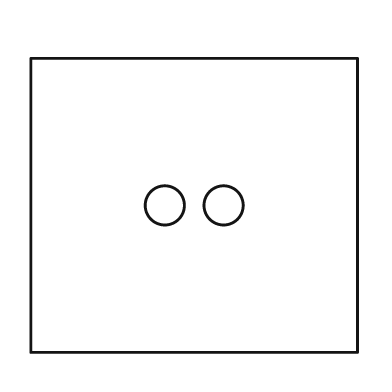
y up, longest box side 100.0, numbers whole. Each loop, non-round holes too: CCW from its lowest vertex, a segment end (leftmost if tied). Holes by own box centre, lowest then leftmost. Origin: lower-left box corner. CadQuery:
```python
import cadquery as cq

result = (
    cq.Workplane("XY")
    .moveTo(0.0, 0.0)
    .lineTo(100.0, 0.0)
    .lineTo(100.0, 90.0)
    .lineTo(0.0, 90.0)
    .close()
    .moveTo(41.0, 45.0)
    .circle(6.0)
    .moveTo(59.0, 45.0)
    .circle(6.0)
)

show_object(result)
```